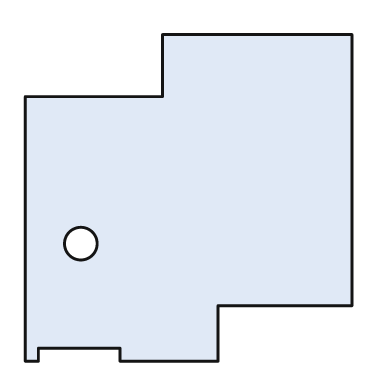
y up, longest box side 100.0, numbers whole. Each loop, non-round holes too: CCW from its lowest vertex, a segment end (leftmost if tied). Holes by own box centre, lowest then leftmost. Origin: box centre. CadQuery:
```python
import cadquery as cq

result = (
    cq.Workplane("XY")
    .moveTo(-50.0, -50.0)
    .lineTo(-46.0, -50.0)
    .lineTo(-46.0, -46.0)
    .lineTo(-21.0, -46.0)
    .lineTo(-21.0, -50.0)
    .lineTo(9.0, -50.0)
    .lineTo(9.0, -33.0)
    .lineTo(50.0, -33.0)
    .lineTo(50.0, 50.0)
    .lineTo(-8.0, 50.0)
    .lineTo(-8.0, 31.0)
    .lineTo(-50.0, 31.0)
    .close()
    .moveTo(-33.0, -14.0)
    .circle(5.0)
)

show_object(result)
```